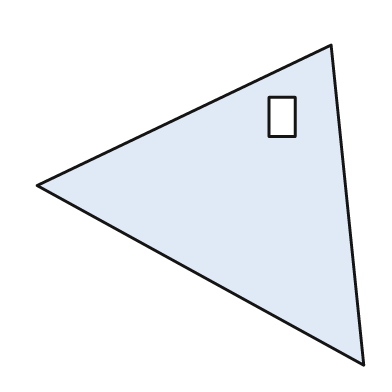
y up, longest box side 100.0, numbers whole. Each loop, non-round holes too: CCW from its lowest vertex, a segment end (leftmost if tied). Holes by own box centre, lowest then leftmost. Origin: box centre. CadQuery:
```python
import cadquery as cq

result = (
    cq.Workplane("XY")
    .moveTo(50.0, -49.0)
    .lineTo(40.0, 49.0)
    .lineTo(-50.0, 6.0)
    .close()
    .moveTo(21.0, 21.0)
    .lineTo(29.0, 21.0)
    .lineTo(29.0, 33.0)
    .lineTo(21.0, 33.0)
    .close()
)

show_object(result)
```